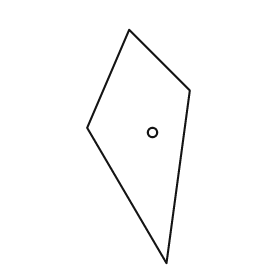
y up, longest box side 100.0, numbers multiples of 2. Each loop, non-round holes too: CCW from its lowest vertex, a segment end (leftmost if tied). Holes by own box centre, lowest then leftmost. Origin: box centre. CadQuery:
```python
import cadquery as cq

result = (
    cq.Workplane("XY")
    .moveTo(12.0, -50.0)
    .lineTo(22.0, 24.0)
    .lineTo(-4.0, 50.0)
    .lineTo(-22.0, 8.0)
    .close()
    .moveTo(6.0, 6.0)
    .circle(2.0)
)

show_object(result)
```